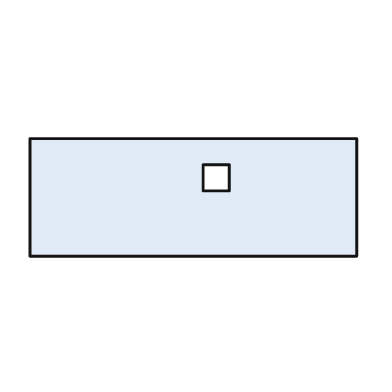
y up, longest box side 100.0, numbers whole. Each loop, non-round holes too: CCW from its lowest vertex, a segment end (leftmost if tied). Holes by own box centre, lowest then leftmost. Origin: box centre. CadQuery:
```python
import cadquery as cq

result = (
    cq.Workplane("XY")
    .moveTo(-50.0, -18.0)
    .lineTo(50.0, -18.0)
    .lineTo(50.0, 18.0)
    .lineTo(-50.0, 18.0)
    .close()
    .moveTo(3.0, 2.0)
    .lineTo(11.0, 2.0)
    .lineTo(11.0, 10.0)
    .lineTo(3.0, 10.0)
    .close()
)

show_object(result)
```